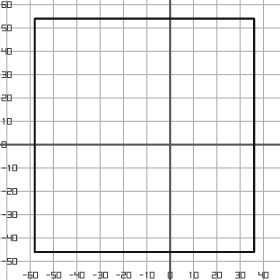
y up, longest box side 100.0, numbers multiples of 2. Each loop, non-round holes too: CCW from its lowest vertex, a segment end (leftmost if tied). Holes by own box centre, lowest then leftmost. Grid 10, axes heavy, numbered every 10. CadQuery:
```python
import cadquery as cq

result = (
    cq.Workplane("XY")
    .moveTo(-58.0, -46.0)
    .lineTo(36.0, -46.0)
    .lineTo(36.0, 54.0)
    .lineTo(-58.0, 54.0)
    .close()
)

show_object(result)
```